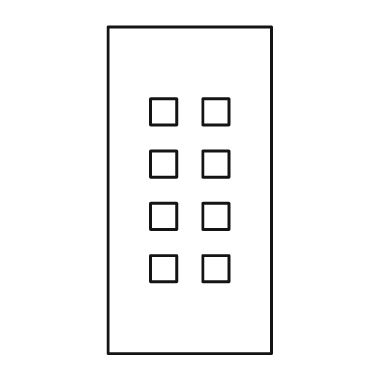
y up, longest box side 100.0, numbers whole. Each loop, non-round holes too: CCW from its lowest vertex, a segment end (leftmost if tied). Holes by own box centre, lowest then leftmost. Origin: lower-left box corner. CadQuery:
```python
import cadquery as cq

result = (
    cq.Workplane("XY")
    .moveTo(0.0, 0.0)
    .lineTo(50.0, 0.0)
    .lineTo(50.0, 100.0)
    .lineTo(0.0, 100.0)
    .close()
    .moveTo(13.0, 22.0)
    .lineTo(21.0, 22.0)
    .lineTo(21.0, 30.0)
    .lineTo(13.0, 30.0)
    .close()
    .moveTo(29.0, 22.0)
    .lineTo(37.0, 22.0)
    .lineTo(37.0, 30.0)
    .lineTo(29.0, 30.0)
    .close()
    .moveTo(13.0, 38.0)
    .lineTo(21.0, 38.0)
    .lineTo(21.0, 46.0)
    .lineTo(13.0, 46.0)
    .close()
    .moveTo(29.0, 38.0)
    .lineTo(37.0, 38.0)
    .lineTo(37.0, 46.0)
    .lineTo(29.0, 46.0)
    .close()
    .moveTo(13.0, 54.0)
    .lineTo(21.0, 54.0)
    .lineTo(21.0, 62.0)
    .lineTo(13.0, 62.0)
    .close()
    .moveTo(29.0, 54.0)
    .lineTo(37.0, 54.0)
    .lineTo(37.0, 62.0)
    .lineTo(29.0, 62.0)
    .close()
    .moveTo(13.0, 70.0)
    .lineTo(21.0, 70.0)
    .lineTo(21.0, 78.0)
    .lineTo(13.0, 78.0)
    .close()
    .moveTo(29.0, 70.0)
    .lineTo(37.0, 70.0)
    .lineTo(37.0, 78.0)
    .lineTo(29.0, 78.0)
    .close()
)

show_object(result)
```